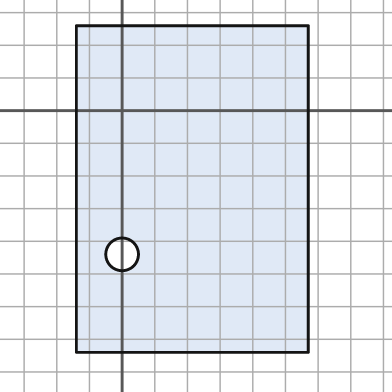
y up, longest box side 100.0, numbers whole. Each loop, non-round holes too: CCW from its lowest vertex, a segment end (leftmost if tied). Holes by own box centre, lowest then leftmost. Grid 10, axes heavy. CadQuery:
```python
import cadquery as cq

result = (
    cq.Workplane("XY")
    .moveTo(-14.0, -74.0)
    .lineTo(57.0, -74.0)
    .lineTo(57.0, 26.0)
    .lineTo(-14.0, 26.0)
    .close()
    .moveTo(0.0, -44.0)
    .circle(5.0)
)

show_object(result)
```